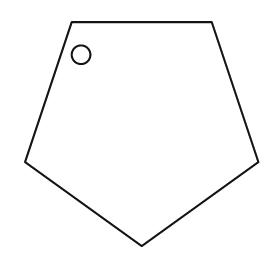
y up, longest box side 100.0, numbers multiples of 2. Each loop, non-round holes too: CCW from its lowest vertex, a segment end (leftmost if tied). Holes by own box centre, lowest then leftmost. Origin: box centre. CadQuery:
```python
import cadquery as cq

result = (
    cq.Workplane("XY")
    .moveTo(0.0, -48.0)
    .lineTo(50.0, -12.0)
    .lineTo(30.0, 48.0)
    .lineTo(-30.0, 48.0)
    .lineTo(-50.0, -12.0)
    .close()
    .moveTo(-26.0, 34.0)
    .circle(4.0)
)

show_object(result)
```